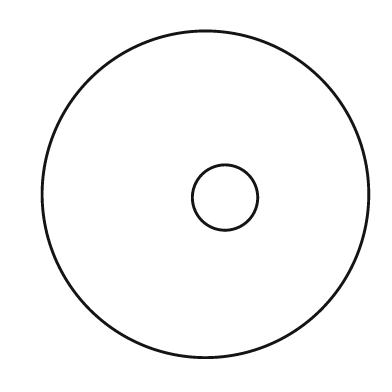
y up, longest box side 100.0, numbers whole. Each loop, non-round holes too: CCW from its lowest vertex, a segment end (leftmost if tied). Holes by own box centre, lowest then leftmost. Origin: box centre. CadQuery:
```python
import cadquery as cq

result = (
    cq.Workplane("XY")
    .moveTo(0.0, 0.0)
    .circle(50.0)
    .moveTo(6.0, -1.0)
    .circle(10.0)
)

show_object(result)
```